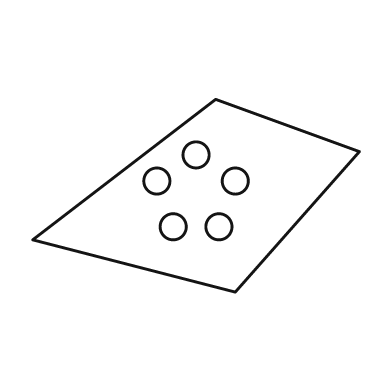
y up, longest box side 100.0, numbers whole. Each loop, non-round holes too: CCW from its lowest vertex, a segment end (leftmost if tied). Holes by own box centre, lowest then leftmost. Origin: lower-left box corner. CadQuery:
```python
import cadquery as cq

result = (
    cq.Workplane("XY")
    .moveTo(62.0, 0.0)
    .lineTo(100.0, 43.0)
    .lineTo(56.0, 59.0)
    .lineTo(0.0, 16.0)
    .close()
    .moveTo(43.0, 20.0)
    .circle(4.0)
    .moveTo(57.0, 20.0)
    .circle(4.0)
    .moveTo(38.0, 34.0)
    .circle(4.0)
    .moveTo(62.0, 34.0)
    .circle(4.0)
    .moveTo(50.0, 42.0)
    .circle(4.0)
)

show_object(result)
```